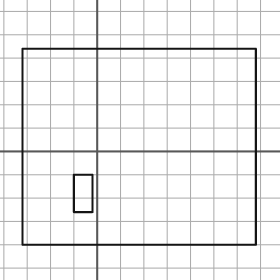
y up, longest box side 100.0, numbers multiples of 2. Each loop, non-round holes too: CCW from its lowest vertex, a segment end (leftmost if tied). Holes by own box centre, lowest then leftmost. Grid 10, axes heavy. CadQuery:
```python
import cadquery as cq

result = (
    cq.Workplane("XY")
    .moveTo(-32.0, -40.0)
    .lineTo(68.0, -40.0)
    .lineTo(68.0, 44.0)
    .lineTo(-32.0, 44.0)
    .close()
    .moveTo(-10.0, -26.0)
    .lineTo(-2.0, -26.0)
    .lineTo(-2.0, -10.0)
    .lineTo(-10.0, -10.0)
    .close()
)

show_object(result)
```